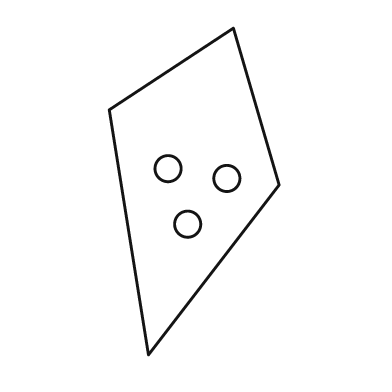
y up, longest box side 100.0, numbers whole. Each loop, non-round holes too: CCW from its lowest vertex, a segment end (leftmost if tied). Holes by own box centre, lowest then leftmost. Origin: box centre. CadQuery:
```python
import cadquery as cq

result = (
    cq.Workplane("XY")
    .moveTo(-14.0, -50.0)
    .lineTo(26.0, 2.0)
    .lineTo(12.0, 50.0)
    .lineTo(-26.0, 25.0)
    .close()
    .moveTo(-2.0, -10.0)
    .circle(4.0)
    .moveTo(10.0, 4.0)
    .circle(4.0)
    .moveTo(-8.0, 7.0)
    .circle(4.0)
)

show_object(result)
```